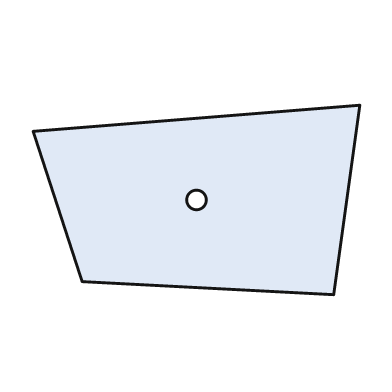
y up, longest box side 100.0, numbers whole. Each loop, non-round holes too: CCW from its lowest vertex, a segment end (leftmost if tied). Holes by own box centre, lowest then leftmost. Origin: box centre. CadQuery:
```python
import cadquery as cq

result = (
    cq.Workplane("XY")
    .moveTo(42.0, -29.0)
    .lineTo(50.0, 29.0)
    .lineTo(-50.0, 21.0)
    .lineTo(-35.0, -25.0)
    .close()
    .moveTo(0.0, 0.0)
    .circle(3.0)
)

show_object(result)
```